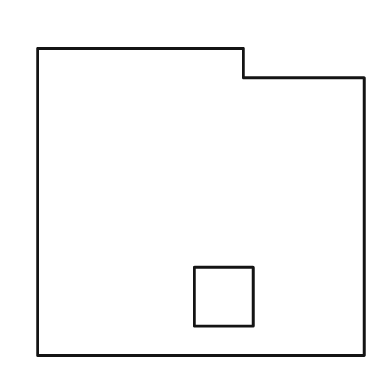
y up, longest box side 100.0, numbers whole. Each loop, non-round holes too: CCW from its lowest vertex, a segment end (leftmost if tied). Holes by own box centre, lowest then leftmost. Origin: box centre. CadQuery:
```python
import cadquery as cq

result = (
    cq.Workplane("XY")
    .moveTo(-50.0, -47.0)
    .lineTo(50.0, -47.0)
    .lineTo(50.0, 38.0)
    .lineTo(13.0, 38.0)
    .lineTo(13.0, 47.0)
    .lineTo(-50.0, 47.0)
    .close()
    .moveTo(-2.0, -38.0)
    .lineTo(16.0, -38.0)
    .lineTo(16.0, -20.0)
    .lineTo(-2.0, -20.0)
    .close()
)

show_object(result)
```